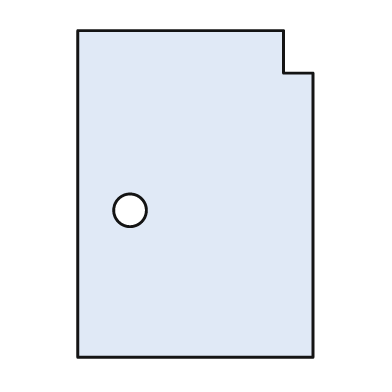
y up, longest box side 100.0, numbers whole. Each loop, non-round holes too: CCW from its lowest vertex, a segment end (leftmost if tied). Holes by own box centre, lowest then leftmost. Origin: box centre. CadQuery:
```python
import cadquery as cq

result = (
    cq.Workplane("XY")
    .moveTo(-36.0, -50.0)
    .lineTo(36.0, -50.0)
    .lineTo(36.0, 37.0)
    .lineTo(27.0, 37.0)
    .lineTo(27.0, 50.0)
    .lineTo(-36.0, 50.0)
    .close()
    .moveTo(-20.0, -5.0)
    .circle(5.0)
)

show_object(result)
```